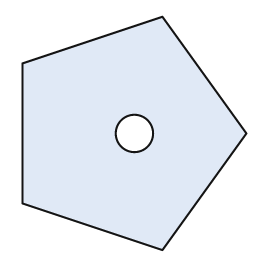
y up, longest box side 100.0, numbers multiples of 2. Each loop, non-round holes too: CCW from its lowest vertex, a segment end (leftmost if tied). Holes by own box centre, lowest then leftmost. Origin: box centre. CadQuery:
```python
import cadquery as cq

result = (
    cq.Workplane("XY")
    .moveTo(12.0, -50.0)
    .lineTo(48.0, 0.0)
    .lineTo(12.0, 50.0)
    .lineTo(-48.0, 30.0)
    .lineTo(-48.0, -30.0)
    .close()
    .moveTo(0.0, 0.0)
    .circle(8.0)
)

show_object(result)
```